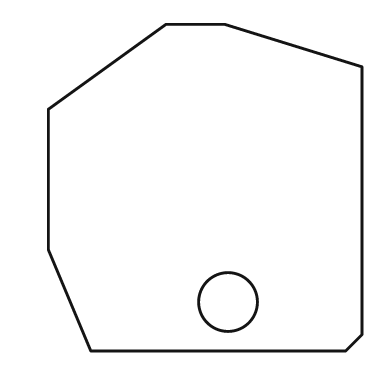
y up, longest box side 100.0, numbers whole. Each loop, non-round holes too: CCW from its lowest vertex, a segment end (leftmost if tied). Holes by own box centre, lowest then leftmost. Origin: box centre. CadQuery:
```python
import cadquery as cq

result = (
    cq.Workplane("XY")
    .moveTo(-35.0, -50.0)
    .lineTo(43.0, -50.0)
    .lineTo(48.0, -45.0)
    .lineTo(48.0, 37.0)
    .lineTo(6.0, 50.0)
    .lineTo(-12.0, 50.0)
    .lineTo(-48.0, 24.0)
    .lineTo(-48.0, -19.0)
    .close()
    .moveTo(7.0, -35.0)
    .circle(9.0)
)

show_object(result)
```